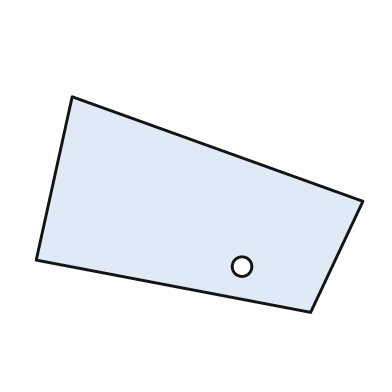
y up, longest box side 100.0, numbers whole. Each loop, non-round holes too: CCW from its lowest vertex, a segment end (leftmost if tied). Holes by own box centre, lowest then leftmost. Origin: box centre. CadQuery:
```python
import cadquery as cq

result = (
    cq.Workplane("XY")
    .moveTo(34.0, -33.0)
    .lineTo(50.0, 1.0)
    .lineTo(-39.0, 33.0)
    .lineTo(-50.0, -17.0)
    .close()
    .moveTo(13.0, -19.0)
    .circle(3.0)
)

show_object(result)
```